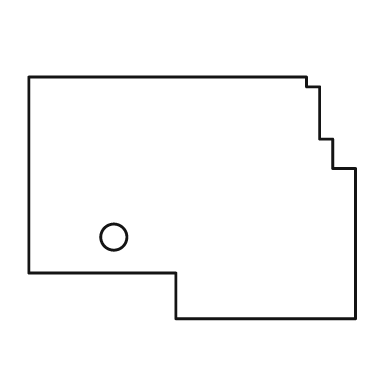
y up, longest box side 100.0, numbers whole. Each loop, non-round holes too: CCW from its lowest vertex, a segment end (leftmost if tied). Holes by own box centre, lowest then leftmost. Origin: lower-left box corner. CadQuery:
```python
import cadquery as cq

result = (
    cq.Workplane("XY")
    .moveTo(45.0, 0.0)
    .lineTo(100.0, 0.0)
    .lineTo(100.0, 46.0)
    .lineTo(93.0, 46.0)
    .lineTo(93.0, 55.0)
    .lineTo(89.0, 55.0)
    .lineTo(89.0, 71.0)
    .lineTo(85.0, 71.0)
    .lineTo(85.0, 74.0)
    .lineTo(0.0, 74.0)
    .lineTo(0.0, 14.0)
    .lineTo(45.0, 14.0)
    .close()
    .moveTo(26.0, 25.0)
    .circle(4.0)
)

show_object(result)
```